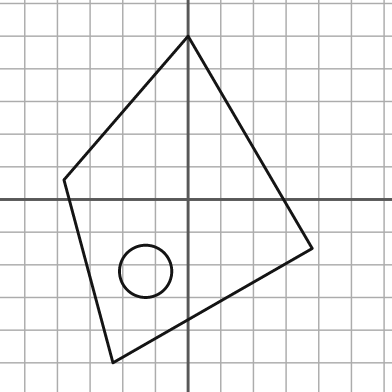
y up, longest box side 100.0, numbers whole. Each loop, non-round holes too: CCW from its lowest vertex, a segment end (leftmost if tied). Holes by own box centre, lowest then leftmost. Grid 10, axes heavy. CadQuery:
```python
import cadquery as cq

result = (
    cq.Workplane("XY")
    .moveTo(-23.0, -50.0)
    .lineTo(38.0, -15.0)
    .lineTo(0.0, 50.0)
    .lineTo(-38.0, 6.0)
    .close()
    .moveTo(-13.0, -22.0)
    .circle(8.0)
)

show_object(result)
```